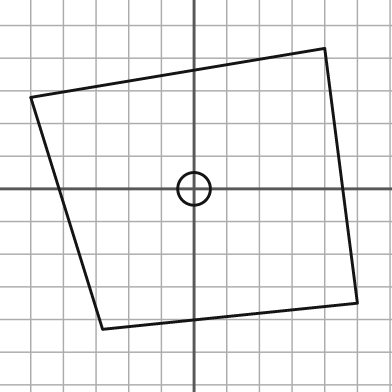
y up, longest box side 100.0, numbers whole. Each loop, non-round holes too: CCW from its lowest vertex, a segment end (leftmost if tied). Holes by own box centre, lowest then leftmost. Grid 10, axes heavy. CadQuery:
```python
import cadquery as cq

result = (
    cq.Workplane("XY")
    .moveTo(-28.0, -43.0)
    .lineTo(50.0, -35.0)
    .lineTo(40.0, 43.0)
    .lineTo(-50.0, 28.0)
    .close()
    .moveTo(0.0, 0.0)
    .circle(5.0)
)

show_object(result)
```